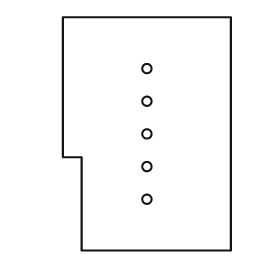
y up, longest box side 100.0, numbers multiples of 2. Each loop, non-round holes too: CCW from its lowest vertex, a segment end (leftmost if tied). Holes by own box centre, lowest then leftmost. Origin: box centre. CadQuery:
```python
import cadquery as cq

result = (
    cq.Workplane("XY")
    .moveTo(-28.0, -50.0)
    .lineTo(36.0, -50.0)
    .lineTo(36.0, 50.0)
    .lineTo(-36.0, 50.0)
    .lineTo(-36.0, -10.0)
    .lineTo(-28.0, -10.0)
    .close()
    .moveTo(0.0, -28.0)
    .circle(2.0)
    .moveTo(0.0, -14.0)
    .circle(2.0)
    .moveTo(0.0, 0.0)
    .circle(2.0)
    .moveTo(0.0, 14.0)
    .circle(2.0)
    .moveTo(0.0, 28.0)
    .circle(2.0)
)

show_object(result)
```